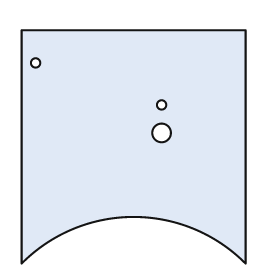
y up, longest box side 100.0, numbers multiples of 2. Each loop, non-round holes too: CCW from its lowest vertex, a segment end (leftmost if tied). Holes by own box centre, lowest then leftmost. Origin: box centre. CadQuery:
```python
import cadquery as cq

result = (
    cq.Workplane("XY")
    .moveTo(-48.0, -50.0)
    .threePointArc((0.0, -30.0), (48.0, -50.0))
    .lineTo(48.0, 50.0)
    .lineTo(-48.0, 50.0)
    .close()
    .moveTo(12.0, 6.0)
    .circle(4.0)
    .moveTo(12.0, 18.0)
    .circle(2.0)
    .moveTo(-42.0, 36.0)
    .circle(2.0)
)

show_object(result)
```